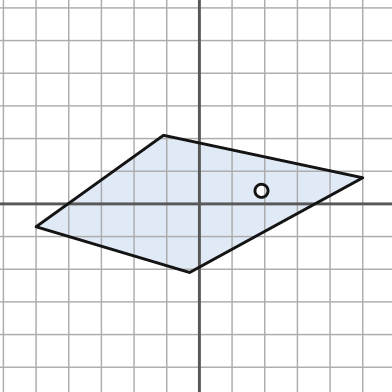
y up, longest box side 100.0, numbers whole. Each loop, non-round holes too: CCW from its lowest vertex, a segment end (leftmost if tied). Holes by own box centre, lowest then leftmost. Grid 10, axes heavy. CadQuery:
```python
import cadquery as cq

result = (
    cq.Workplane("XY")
    .moveTo(-3.0, -21.0)
    .lineTo(50.0, 8.0)
    .lineTo(-11.0, 21.0)
    .lineTo(-50.0, -7.0)
    .close()
    .moveTo(19.0, 4.0)
    .circle(2.0)
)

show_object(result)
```